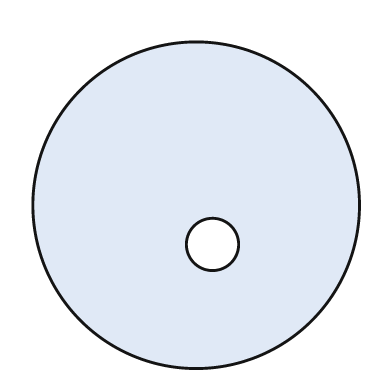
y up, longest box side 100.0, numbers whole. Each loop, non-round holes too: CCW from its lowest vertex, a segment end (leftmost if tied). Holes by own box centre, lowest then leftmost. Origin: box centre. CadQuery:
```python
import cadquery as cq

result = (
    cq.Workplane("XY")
    .moveTo(0.0, 0.0)
    .circle(50.0)
    .moveTo(5.0, -12.0)
    .circle(8.0)
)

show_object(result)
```